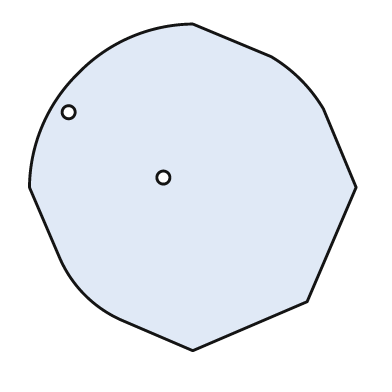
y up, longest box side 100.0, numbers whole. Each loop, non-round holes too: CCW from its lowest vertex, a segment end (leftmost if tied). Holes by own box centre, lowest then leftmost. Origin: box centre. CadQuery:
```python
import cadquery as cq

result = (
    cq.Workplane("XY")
    .moveTo(0.0, -50.0)
    .lineTo(35.0, -35.0)
    .lineTo(50.0, 0.0)
    .lineTo(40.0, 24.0)
    .threePointArc((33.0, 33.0), (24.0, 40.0))
    .lineTo(0.0, 50.0)
    .threePointArc((-19.0, 46.0), (-35.0, 35.0))
    .threePointArc((-46.0, 19.0), (-50.0, 0.0))
    .lineTo(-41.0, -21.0)
    .threePointArc((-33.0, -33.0), (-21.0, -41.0))
    .close()
    .moveTo(-9.0, 3.0)
    .circle(2.0)
    .moveTo(-38.0, 23.0)
    .circle(2.0)
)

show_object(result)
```